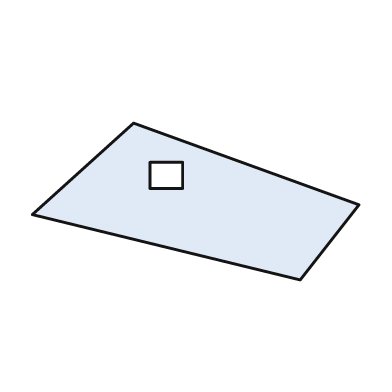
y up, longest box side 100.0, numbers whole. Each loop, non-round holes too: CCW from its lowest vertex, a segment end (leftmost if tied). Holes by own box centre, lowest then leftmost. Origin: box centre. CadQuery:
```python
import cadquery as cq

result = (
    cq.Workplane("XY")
    .moveTo(32.0, -24.0)
    .lineTo(50.0, -1.0)
    .lineTo(-19.0, 24.0)
    .lineTo(-50.0, -4.0)
    .close()
    .moveTo(-14.0, 4.0)
    .lineTo(-4.0, 4.0)
    .lineTo(-4.0, 12.0)
    .lineTo(-14.0, 12.0)
    .close()
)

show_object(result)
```